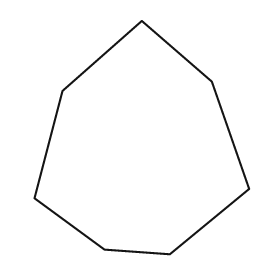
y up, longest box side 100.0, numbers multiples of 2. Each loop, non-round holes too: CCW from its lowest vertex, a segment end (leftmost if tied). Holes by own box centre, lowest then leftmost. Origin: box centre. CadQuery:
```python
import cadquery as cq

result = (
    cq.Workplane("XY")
    .moveTo(12.0, -50.0)
    .lineTo(46.0, -22.0)
    .lineTo(30.0, 24.0)
    .lineTo(0.0, 50.0)
    .lineTo(-34.0, 20.0)
    .lineTo(-46.0, -26.0)
    .lineTo(-16.0, -48.0)
    .close()
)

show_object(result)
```